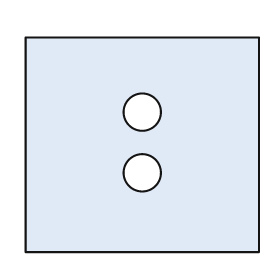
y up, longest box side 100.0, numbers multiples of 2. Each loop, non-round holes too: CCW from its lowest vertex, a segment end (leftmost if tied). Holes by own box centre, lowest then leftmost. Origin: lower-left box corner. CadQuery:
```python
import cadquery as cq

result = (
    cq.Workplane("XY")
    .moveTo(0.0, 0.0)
    .lineTo(100.0, 0.0)
    .lineTo(100.0, 92.0)
    .lineTo(0.0, 92.0)
    .close()
    .moveTo(50.0, 34.0)
    .circle(8.0)
    .moveTo(50.0, 60.0)
    .circle(8.0)
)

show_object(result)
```